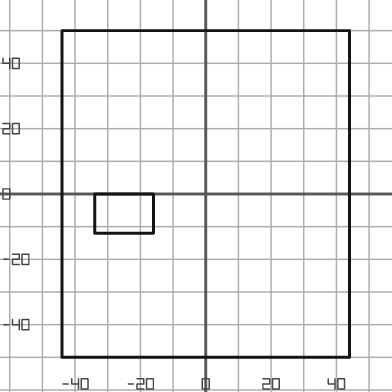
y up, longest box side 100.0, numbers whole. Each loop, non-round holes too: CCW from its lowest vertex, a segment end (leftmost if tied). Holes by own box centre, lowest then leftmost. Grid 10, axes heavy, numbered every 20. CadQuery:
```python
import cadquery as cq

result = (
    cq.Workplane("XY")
    .moveTo(-44.0, -50.0)
    .lineTo(44.0, -50.0)
    .lineTo(44.0, 50.0)
    .lineTo(-44.0, 50.0)
    .close()
    .moveTo(-34.0, -12.0)
    .lineTo(-16.0, -12.0)
    .lineTo(-16.0, 0.0)
    .lineTo(-34.0, 0.0)
    .close()
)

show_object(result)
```